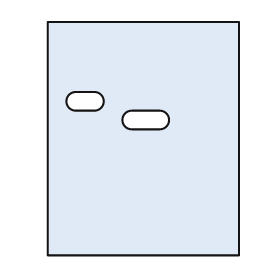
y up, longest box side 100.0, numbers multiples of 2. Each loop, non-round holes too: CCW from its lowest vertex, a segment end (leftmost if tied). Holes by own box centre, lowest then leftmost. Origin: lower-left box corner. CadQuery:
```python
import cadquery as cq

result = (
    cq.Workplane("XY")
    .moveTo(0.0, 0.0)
    .lineTo(82.0, 0.0)
    .lineTo(82.0, 100.0)
    .lineTo(0.0, 100.0)
    .close()
    .moveTo(36.0, 54.0)
    .lineTo(48.0, 54.0)
    .threePointArc((52.0, 58.0), (48.0, 62.0))
    .lineTo(36.0, 62.0)
    .threePointArc((32.0, 58.0), (36.0, 54.0))
    .close()
    .moveTo(12.0, 62.0)
    .lineTo(20.0, 62.0)
    .threePointArc((24.0, 66.0), (20.0, 70.0))
    .lineTo(12.0, 70.0)
    .threePointArc((8.0, 66.0), (12.0, 62.0))
    .close()
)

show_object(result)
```